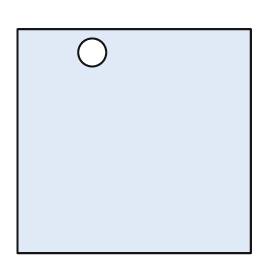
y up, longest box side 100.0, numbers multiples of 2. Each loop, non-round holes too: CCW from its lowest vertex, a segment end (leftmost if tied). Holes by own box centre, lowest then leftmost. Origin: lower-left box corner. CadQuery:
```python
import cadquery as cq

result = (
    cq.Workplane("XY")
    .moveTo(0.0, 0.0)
    .lineTo(100.0, 0.0)
    .lineTo(100.0, 96.0)
    .lineTo(0.0, 96.0)
    .close()
    .moveTo(32.0, 86.0)
    .circle(6.0)
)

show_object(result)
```